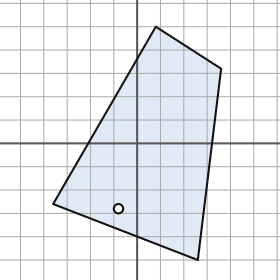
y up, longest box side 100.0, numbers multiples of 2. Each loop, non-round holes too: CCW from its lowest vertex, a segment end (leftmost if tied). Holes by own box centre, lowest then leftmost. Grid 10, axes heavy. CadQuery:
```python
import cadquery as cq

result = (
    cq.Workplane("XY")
    .moveTo(26.0, -50.0)
    .lineTo(36.0, 32.0)
    .lineTo(8.0, 50.0)
    .lineTo(-36.0, -26.0)
    .close()
    .moveTo(-8.0, -28.0)
    .circle(2.0)
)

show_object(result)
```